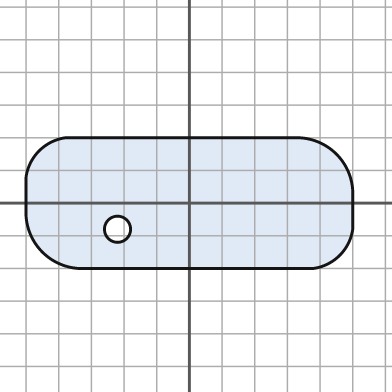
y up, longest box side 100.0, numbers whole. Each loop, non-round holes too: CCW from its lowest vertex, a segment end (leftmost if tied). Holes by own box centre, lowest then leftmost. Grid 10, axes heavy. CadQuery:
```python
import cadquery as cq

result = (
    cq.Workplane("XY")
    .moveTo(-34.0, -20.0)
    .lineTo(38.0, -20.0)
    .threePointArc((46.0, -16.0), (50.0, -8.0))
    .lineTo(50.0, 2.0)
    .threePointArc((45.0, 15.0), (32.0, 20.0))
    .lineTo(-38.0, 20.0)
    .threePointArc((-46.0, 16.0), (-50.0, 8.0))
    .lineTo(-50.0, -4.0)
    .threePointArc((-45.0, -15.0), (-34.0, -20.0))
    .close()
    .moveTo(-22.0, -8.0)
    .circle(4.0)
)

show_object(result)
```